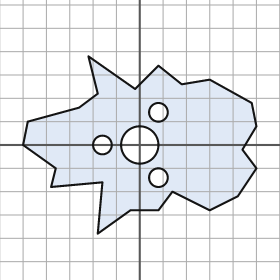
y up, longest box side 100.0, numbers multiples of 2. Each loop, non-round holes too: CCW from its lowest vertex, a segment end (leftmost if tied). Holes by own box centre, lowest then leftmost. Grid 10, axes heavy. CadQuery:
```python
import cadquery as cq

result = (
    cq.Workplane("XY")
    .moveTo(-18.0, -38.0)
    .lineTo(-4.0, -28.0)
    .lineTo(8.0, -28.0)
    .lineTo(14.0, -20.0)
    .lineTo(30.0, -28.0)
    .lineTo(42.0, -22.0)
    .lineTo(50.0, -10.0)
    .lineTo(44.0, -2.0)
    .lineTo(50.0, 8.0)
    .lineTo(48.0, 18.0)
    .lineTo(30.0, 28.0)
    .lineTo(18.0, 26.0)
    .lineTo(8.0, 34.0)
    .lineTo(-2.0, 24.0)
    .lineTo(-22.0, 38.0)
    .lineTo(-18.0, 22.0)
    .lineTo(-26.0, 16.0)
    .lineTo(-48.0, 10.0)
    .lineTo(-50.0, 0.0)
    .lineTo(-36.0, -10.0)
    .lineTo(-38.0, -18.0)
    .lineTo(-16.0, -16.0)
    .close()
    .moveTo(8.0, -14.0)
    .circle(4.0)
    .moveTo(-16.0, 0.0)
    .circle(4.0)
    .moveTo(0.0, 0.0)
    .circle(8.0)
    .moveTo(8.0, 14.0)
    .circle(4.0)
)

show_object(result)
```